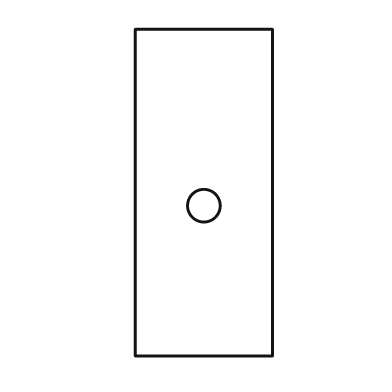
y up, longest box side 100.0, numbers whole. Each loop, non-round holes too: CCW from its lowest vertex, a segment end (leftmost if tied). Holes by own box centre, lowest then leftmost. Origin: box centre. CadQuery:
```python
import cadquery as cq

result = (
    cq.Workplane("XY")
    .moveTo(-21.0, -50.0)
    .lineTo(21.0, -50.0)
    .lineTo(21.0, 50.0)
    .lineTo(-21.0, 50.0)
    .close()
    .moveTo(0.0, -4.0)
    .circle(5.0)
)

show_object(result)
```